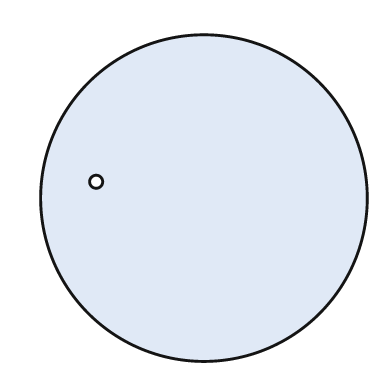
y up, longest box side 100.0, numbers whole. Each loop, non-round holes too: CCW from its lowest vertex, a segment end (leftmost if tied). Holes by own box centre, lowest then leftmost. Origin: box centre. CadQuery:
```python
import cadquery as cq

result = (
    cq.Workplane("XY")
    .moveTo(0.0, 0.0)
    .circle(50.0)
    .moveTo(-33.0, 5.0)
    .circle(2.0)
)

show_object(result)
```